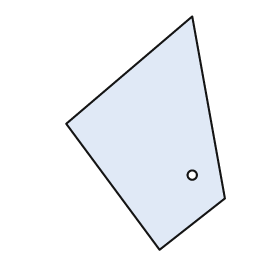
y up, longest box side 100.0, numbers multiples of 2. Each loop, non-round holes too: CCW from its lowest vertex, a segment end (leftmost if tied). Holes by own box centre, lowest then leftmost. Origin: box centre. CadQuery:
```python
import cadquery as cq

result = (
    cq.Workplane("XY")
    .moveTo(6.0, -50.0)
    .lineTo(34.0, -28.0)
    .lineTo(20.0, 50.0)
    .lineTo(-34.0, 4.0)
    .close()
    .moveTo(20.0, -18.0)
    .circle(2.0)
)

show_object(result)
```